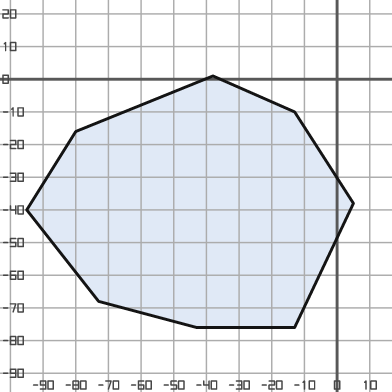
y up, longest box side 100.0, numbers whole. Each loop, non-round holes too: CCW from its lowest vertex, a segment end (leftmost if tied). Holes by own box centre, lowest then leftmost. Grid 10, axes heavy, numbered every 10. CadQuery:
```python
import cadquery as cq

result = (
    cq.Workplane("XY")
    .moveTo(-43.0, -76.0)
    .lineTo(-13.0, -76.0)
    .lineTo(5.0, -38.0)
    .lineTo(-13.0, -10.0)
    .lineTo(-38.0, 1.0)
    .lineTo(-80.0, -16.0)
    .lineTo(-95.0, -40.0)
    .lineTo(-73.0, -68.0)
    .close()
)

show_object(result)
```